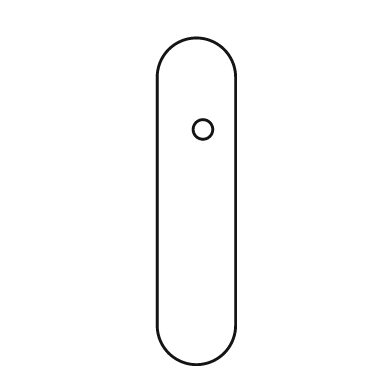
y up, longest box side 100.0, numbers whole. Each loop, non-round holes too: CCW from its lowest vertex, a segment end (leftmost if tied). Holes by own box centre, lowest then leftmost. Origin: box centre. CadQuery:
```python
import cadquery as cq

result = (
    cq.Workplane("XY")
    .moveTo(-12.0, -38.0)
    .threePointArc((0.0, -50.0), (12.0, -38.0))
    .lineTo(12.0, 38.0)
    .threePointArc((0.0, 50.0), (-12.0, 38.0))
    .close()
    .moveTo(2.0, 22.0)
    .circle(3.0)
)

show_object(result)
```